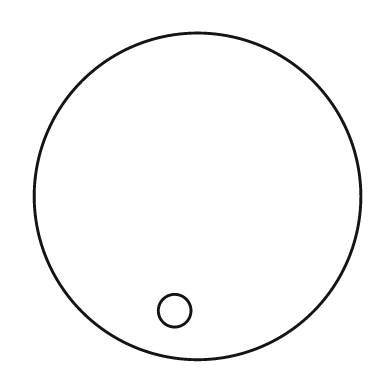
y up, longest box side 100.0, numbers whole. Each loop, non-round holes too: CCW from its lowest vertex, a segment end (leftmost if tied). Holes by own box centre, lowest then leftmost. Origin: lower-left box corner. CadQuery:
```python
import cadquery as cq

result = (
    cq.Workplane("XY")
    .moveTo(50.0, 50.0)
    .circle(50.0)
    .moveTo(43.0, 15.0)
    .circle(5.0)
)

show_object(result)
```